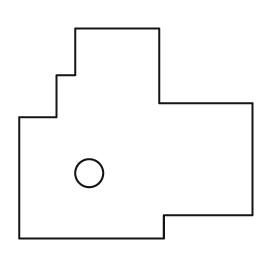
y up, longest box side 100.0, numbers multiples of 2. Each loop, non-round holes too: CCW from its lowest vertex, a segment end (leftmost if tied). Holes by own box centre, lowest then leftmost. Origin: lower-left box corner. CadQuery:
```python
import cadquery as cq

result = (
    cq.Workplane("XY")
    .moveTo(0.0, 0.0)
    .lineTo(62.0, 0.0)
    .lineTo(62.0, 10.0)
    .lineTo(100.0, 10.0)
    .lineTo(100.0, 58.0)
    .lineTo(60.0, 58.0)
    .lineTo(60.0, 90.0)
    .lineTo(24.0, 90.0)
    .lineTo(24.0, 70.0)
    .lineTo(16.0, 70.0)
    .lineTo(16.0, 52.0)
    .lineTo(0.0, 52.0)
    .close()
    .moveTo(30.0, 28.0)
    .circle(6.0)
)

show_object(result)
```